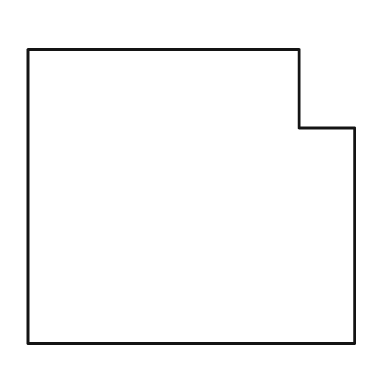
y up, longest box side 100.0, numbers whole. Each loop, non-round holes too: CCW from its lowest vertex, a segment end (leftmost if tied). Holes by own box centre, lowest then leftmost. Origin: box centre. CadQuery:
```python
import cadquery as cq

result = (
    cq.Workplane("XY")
    .moveTo(-50.0, -45.0)
    .lineTo(50.0, -45.0)
    .lineTo(50.0, 21.0)
    .lineTo(33.0, 21.0)
    .lineTo(33.0, 45.0)
    .lineTo(-50.0, 45.0)
    .close()
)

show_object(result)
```